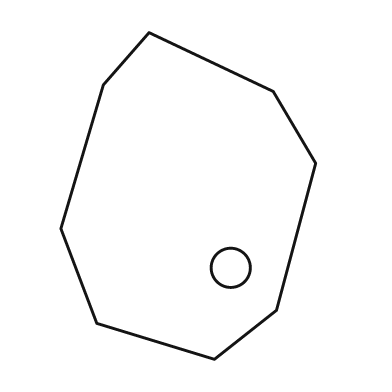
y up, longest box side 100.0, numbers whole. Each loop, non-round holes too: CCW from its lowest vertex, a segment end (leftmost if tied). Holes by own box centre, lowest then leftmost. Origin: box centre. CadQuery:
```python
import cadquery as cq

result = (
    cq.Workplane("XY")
    .moveTo(8.0, -50.0)
    .lineTo(27.0, -35.0)
    .lineTo(39.0, 10.0)
    .lineTo(26.0, 32.0)
    .lineTo(-12.0, 50.0)
    .lineTo(-26.0, 34.0)
    .lineTo(-39.0, -10.0)
    .lineTo(-28.0, -39.0)
    .close()
    .moveTo(13.0, -22.0)
    .circle(6.0)
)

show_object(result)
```